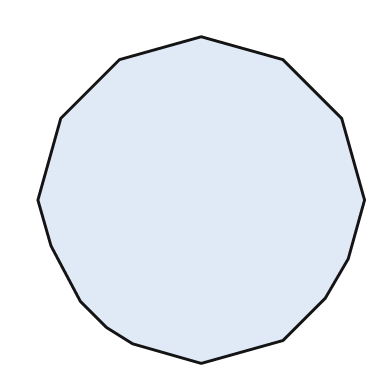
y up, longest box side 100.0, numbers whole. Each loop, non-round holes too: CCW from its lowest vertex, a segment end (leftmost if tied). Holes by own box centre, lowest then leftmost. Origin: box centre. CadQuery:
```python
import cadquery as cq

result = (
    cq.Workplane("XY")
    .moveTo(0.0, -50.0)
    .lineTo(25.0, -43.0)
    .lineTo(38.0, -30.0)
    .lineTo(45.0, -18.0)
    .lineTo(50.0, 0.0)
    .lineTo(43.0, 25.0)
    .lineTo(25.0, 43.0)
    .lineTo(0.0, 50.0)
    .lineTo(-25.0, 43.0)
    .lineTo(-43.0, 25.0)
    .lineTo(-50.0, 0.0)
    .lineTo(-46.0, -14.0)
    .lineTo(-37.0, -31.0)
    .lineTo(-29.0, -39.0)
    .lineTo(-21.0, -44.0)
    .close()
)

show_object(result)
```